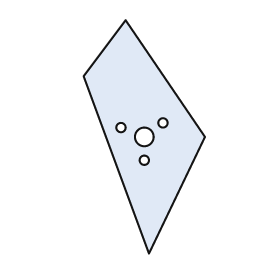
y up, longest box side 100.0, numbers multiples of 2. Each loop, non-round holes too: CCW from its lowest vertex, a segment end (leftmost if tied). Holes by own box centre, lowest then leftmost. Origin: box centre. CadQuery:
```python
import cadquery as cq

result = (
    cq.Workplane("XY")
    .moveTo(2.0, -50.0)
    .lineTo(26.0, 0.0)
    .lineTo(-8.0, 50.0)
    .lineTo(-26.0, 26.0)
    .close()
    .moveTo(0.0, -10.0)
    .circle(2.0)
    .moveTo(0.0, 0.0)
    .circle(4.0)
    .moveTo(-10.0, 4.0)
    .circle(2.0)
    .moveTo(8.0, 6.0)
    .circle(2.0)
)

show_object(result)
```